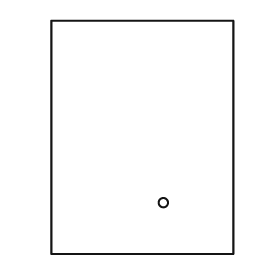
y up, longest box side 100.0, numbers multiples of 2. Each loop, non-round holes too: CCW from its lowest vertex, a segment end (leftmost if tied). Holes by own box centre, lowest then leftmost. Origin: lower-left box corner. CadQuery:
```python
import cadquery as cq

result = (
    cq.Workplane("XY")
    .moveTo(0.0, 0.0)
    .lineTo(78.0, 0.0)
    .lineTo(78.0, 100.0)
    .lineTo(0.0, 100.0)
    .close()
    .moveTo(48.0, 22.0)
    .circle(2.0)
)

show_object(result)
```